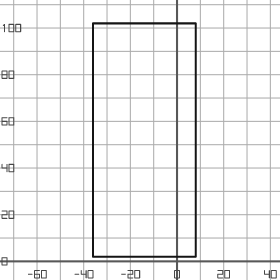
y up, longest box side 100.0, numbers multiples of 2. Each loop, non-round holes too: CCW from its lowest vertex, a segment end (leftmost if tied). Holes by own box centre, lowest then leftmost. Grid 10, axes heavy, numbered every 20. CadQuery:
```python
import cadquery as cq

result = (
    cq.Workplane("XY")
    .moveTo(-36.0, 2.0)
    .lineTo(8.0, 2.0)
    .lineTo(8.0, 102.0)
    .lineTo(-36.0, 102.0)
    .close()
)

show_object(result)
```